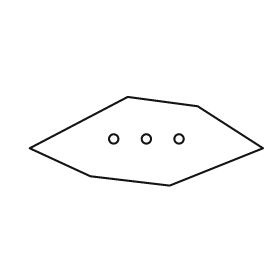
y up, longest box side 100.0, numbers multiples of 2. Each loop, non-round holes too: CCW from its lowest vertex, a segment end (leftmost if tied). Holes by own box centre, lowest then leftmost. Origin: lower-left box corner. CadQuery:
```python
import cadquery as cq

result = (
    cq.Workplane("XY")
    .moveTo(60.0, 0.0)
    .lineTo(100.0, 16.0)
    .lineTo(72.0, 34.0)
    .lineTo(42.0, 38.0)
    .lineTo(0.0, 16.0)
    .lineTo(26.0, 4.0)
    .close()
    .moveTo(36.0, 20.0)
    .circle(2.0)
    .moveTo(50.0, 20.0)
    .circle(2.0)
    .moveTo(64.0, 20.0)
    .circle(2.0)
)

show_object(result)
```